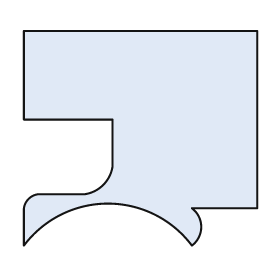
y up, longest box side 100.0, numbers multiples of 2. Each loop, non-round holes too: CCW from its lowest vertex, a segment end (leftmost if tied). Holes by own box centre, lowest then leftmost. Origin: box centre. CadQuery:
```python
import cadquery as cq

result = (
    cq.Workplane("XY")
    .moveTo(-50.0, -46.0)
    .threePointArc((-14.0, -28.0), (22.0, -46.0))
    .threePointArc((26.0, -38.0), (22.0, -30.0))
    .lineTo(50.0, -30.0)
    .lineTo(50.0, 46.0)
    .lineTo(-50.0, 46.0)
    .lineTo(-50.0, 8.0)
    .lineTo(-12.0, 8.0)
    .lineTo(-12.0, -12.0)
    .threePointArc((-16.0, -20.0), (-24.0, -24.0))
    .lineTo(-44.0, -24.0)
    .threePointArc((-48.0, -26.0), (-50.0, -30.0))
    .close()
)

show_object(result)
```